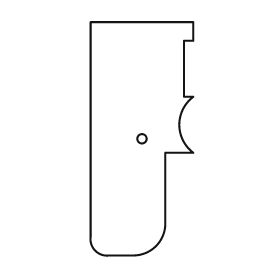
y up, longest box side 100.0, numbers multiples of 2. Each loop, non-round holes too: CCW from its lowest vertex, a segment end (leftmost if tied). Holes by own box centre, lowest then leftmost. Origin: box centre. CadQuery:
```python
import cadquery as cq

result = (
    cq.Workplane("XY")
    .moveTo(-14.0, -50.0)
    .lineTo(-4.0, -50.0)
    .threePointArc((6.0, -46.0), (10.0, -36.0))
    .lineTo(10.0, -6.0)
    .lineTo(22.0, -6.0)
    .threePointArc((16.0, 6.0), (22.0, 18.0))
    .lineTo(18.0, 18.0)
    .lineTo(18.0, 42.0)
    .lineTo(22.0, 42.0)
    .lineTo(22.0, 50.0)
    .lineTo(-22.0, 50.0)
    .lineTo(-22.0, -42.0)
    .threePointArc((-20.0, -48.0), (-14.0, -50.0))
    .close()
    .moveTo(0.0, 0.0)
    .circle(2.0)
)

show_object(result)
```